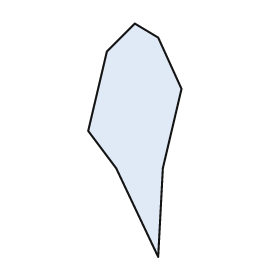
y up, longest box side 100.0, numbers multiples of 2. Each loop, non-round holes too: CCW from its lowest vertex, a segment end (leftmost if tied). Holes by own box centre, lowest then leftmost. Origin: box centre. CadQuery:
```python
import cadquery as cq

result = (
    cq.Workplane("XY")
    .moveTo(10.0, -50.0)
    .lineTo(12.0, -12.0)
    .lineTo(20.0, 22.0)
    .lineTo(10.0, 44.0)
    .lineTo(0.0, 50.0)
    .lineTo(-12.0, 38.0)
    .lineTo(-20.0, 4.0)
    .lineTo(-8.0, -12.0)
    .close()
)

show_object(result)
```